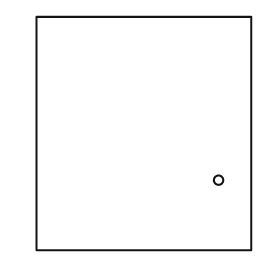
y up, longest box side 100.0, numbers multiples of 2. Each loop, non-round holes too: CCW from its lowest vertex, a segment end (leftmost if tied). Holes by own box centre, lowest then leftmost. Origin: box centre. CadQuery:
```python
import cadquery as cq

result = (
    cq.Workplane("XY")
    .moveTo(-46.0, -50.0)
    .lineTo(46.0, -50.0)
    .lineTo(46.0, 50.0)
    .lineTo(-46.0, 50.0)
    .close()
    .moveTo(32.0, -20.0)
    .circle(2.0)
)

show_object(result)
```